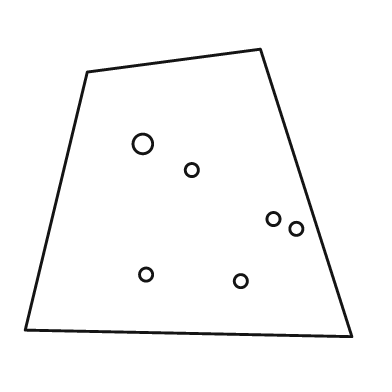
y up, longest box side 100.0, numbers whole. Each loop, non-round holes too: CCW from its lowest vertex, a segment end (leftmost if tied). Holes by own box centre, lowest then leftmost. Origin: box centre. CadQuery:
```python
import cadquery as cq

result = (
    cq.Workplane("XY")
    .moveTo(50.0, -44.0)
    .lineTo(22.0, 44.0)
    .lineTo(-31.0, 37.0)
    .lineTo(-50.0, -42.0)
    .close()
    .moveTo(16.0, -27.0)
    .circle(2.0)
    .moveTo(-13.0, -25.0)
    .circle(2.0)
    .moveTo(33.0, -11.0)
    .circle(2.0)
    .moveTo(26.0, -8.0)
    .circle(2.0)
    .moveTo(1.0, 7.0)
    .circle(2.0)
    .moveTo(-14.0, 15.0)
    .circle(3.0)
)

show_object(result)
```